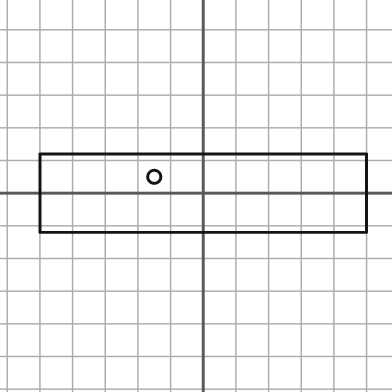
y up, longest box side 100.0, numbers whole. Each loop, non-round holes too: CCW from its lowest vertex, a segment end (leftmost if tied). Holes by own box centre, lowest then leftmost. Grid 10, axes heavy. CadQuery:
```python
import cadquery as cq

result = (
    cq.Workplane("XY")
    .moveTo(-50.0, -12.0)
    .lineTo(50.0, -12.0)
    .lineTo(50.0, 12.0)
    .lineTo(-50.0, 12.0)
    .close()
    .moveTo(-15.0, 5.0)
    .circle(2.0)
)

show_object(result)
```